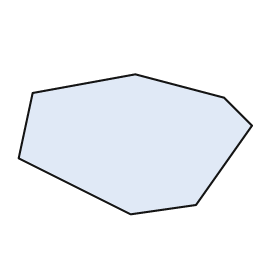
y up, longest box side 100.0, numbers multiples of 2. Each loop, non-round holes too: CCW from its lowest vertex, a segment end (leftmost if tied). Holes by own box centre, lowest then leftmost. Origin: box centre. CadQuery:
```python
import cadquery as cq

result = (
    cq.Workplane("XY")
    .moveTo(-2.0, -30.0)
    .lineTo(26.0, -26.0)
    .lineTo(50.0, 8.0)
    .lineTo(38.0, 20.0)
    .lineTo(0.0, 30.0)
    .lineTo(-44.0, 22.0)
    .lineTo(-50.0, -6.0)
    .close()
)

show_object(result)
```